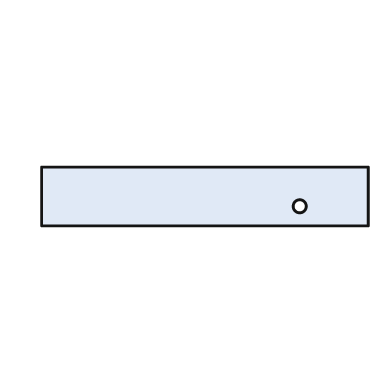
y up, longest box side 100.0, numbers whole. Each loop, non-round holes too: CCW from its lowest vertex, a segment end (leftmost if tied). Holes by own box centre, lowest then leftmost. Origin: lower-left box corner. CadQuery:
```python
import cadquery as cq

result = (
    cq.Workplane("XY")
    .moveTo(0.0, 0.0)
    .lineTo(100.0, 0.0)
    .lineTo(100.0, 18.0)
    .lineTo(0.0, 18.0)
    .close()
    .moveTo(79.0, 6.0)
    .circle(2.0)
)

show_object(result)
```